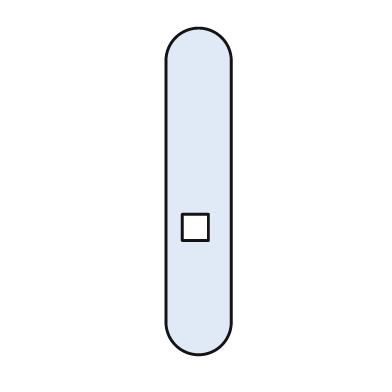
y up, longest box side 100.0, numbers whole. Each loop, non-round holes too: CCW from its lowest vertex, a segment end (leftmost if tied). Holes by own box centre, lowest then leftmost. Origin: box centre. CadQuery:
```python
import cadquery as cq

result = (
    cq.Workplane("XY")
    .moveTo(-10.0, -40.0)
    .threePointArc((0.0, -50.0), (10.0, -40.0))
    .lineTo(10.0, 40.0)
    .threePointArc((0.0, 50.0), (-10.0, 40.0))
    .close()
    .moveTo(-5.0, -15.0)
    .lineTo(3.0, -15.0)
    .lineTo(3.0, -7.0)
    .lineTo(-5.0, -7.0)
    .close()
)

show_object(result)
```